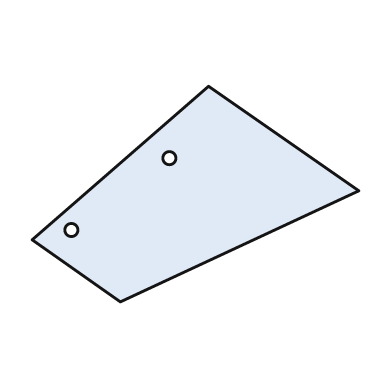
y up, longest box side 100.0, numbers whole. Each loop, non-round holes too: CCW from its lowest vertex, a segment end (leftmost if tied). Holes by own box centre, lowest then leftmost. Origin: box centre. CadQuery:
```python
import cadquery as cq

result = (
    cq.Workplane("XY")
    .moveTo(-23.0, -33.0)
    .lineTo(50.0, 1.0)
    .lineTo(4.0, 33.0)
    .lineTo(-50.0, -14.0)
    .close()
    .moveTo(-38.0, -11.0)
    .circle(2.0)
    .moveTo(-8.0, 11.0)
    .circle(2.0)
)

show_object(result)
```